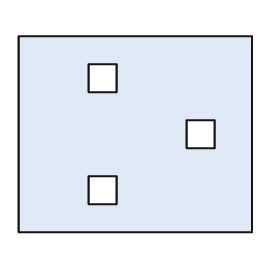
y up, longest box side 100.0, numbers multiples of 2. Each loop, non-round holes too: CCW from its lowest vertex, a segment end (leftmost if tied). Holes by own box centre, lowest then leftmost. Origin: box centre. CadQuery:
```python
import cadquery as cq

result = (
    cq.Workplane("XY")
    .moveTo(-50.0, -42.0)
    .lineTo(50.0, -42.0)
    .lineTo(50.0, 42.0)
    .lineTo(-50.0, 42.0)
    .close()
    .moveTo(-20.0, -30.0)
    .lineTo(-8.0, -30.0)
    .lineTo(-8.0, -18.0)
    .lineTo(-20.0, -18.0)
    .close()
    .moveTo(22.0, -6.0)
    .lineTo(34.0, -6.0)
    .lineTo(34.0, 6.0)
    .lineTo(22.0, 6.0)
    .close()
    .moveTo(-20.0, 18.0)
    .lineTo(-8.0, 18.0)
    .lineTo(-8.0, 30.0)
    .lineTo(-20.0, 30.0)
    .close()
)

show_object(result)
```